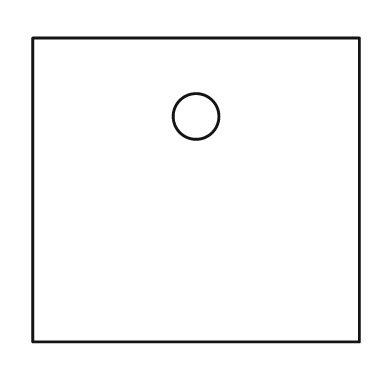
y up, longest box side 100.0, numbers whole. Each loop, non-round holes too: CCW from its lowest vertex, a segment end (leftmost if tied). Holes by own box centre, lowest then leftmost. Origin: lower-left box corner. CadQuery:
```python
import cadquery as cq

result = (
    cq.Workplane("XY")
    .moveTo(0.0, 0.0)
    .lineTo(100.0, 0.0)
    .lineTo(100.0, 93.0)
    .lineTo(0.0, 93.0)
    .close()
    .moveTo(50.0, 69.0)
    .circle(7.0)
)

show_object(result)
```